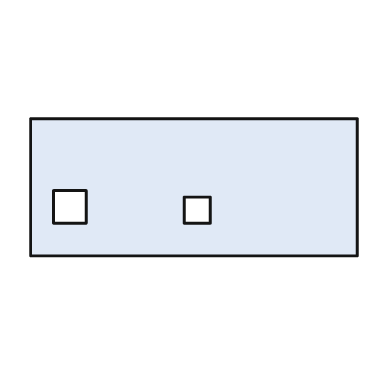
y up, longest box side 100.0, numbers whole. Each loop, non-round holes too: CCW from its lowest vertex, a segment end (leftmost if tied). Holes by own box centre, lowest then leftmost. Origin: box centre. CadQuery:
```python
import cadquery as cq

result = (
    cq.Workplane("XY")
    .moveTo(-50.0, -21.0)
    .lineTo(50.0, -21.0)
    .lineTo(50.0, 21.0)
    .lineTo(-50.0, 21.0)
    .close()
    .moveTo(-3.0, -11.0)
    .lineTo(5.0, -11.0)
    .lineTo(5.0, -3.0)
    .lineTo(-3.0, -3.0)
    .close()
    .moveTo(-43.0, -11.0)
    .lineTo(-33.0, -11.0)
    .lineTo(-33.0, -1.0)
    .lineTo(-43.0, -1.0)
    .close()
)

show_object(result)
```